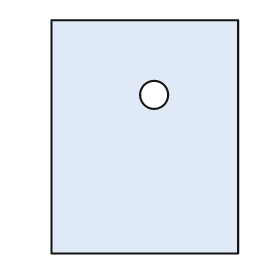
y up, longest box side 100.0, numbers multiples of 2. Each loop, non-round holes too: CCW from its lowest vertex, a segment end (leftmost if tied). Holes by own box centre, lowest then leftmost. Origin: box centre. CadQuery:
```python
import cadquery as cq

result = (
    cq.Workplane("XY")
    .moveTo(-40.0, -50.0)
    .lineTo(40.0, -50.0)
    .lineTo(40.0, 50.0)
    .lineTo(-40.0, 50.0)
    .close()
    .moveTo(4.0, 18.0)
    .circle(6.0)
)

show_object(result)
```